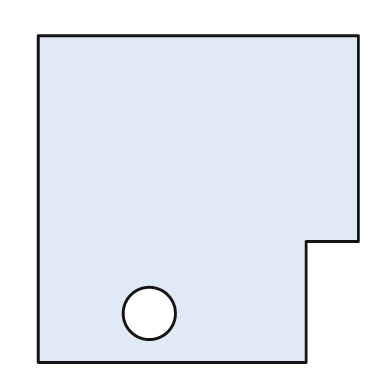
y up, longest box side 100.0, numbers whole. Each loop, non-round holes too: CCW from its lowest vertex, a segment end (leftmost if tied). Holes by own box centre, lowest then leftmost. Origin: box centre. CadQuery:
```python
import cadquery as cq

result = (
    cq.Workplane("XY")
    .moveTo(-49.0, -50.0)
    .lineTo(33.0, -50.0)
    .lineTo(33.0, -13.0)
    .lineTo(49.0, -13.0)
    .lineTo(49.0, 50.0)
    .lineTo(-49.0, 50.0)
    .close()
    .moveTo(-15.0, -35.0)
    .circle(8.0)
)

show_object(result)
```